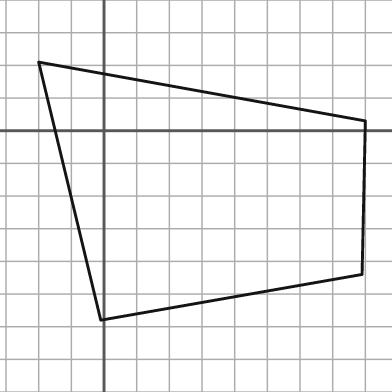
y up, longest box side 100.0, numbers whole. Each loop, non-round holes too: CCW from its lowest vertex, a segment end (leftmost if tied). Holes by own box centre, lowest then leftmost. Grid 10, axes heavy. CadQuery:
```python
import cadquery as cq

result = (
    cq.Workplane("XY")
    .moveTo(-1.0, -58.0)
    .lineTo(79.0, -44.0)
    .lineTo(80.0, 3.0)
    .lineTo(-20.0, 21.0)
    .close()
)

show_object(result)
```